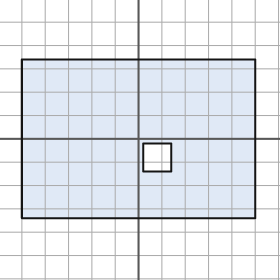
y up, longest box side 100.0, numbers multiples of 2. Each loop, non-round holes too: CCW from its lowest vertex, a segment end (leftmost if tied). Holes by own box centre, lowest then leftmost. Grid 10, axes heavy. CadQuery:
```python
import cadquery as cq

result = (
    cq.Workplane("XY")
    .moveTo(-50.0, -34.0)
    .lineTo(50.0, -34.0)
    .lineTo(50.0, 34.0)
    .lineTo(-50.0, 34.0)
    .close()
    .moveTo(2.0, -14.0)
    .lineTo(14.0, -14.0)
    .lineTo(14.0, -2.0)
    .lineTo(2.0, -2.0)
    .close()
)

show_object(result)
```